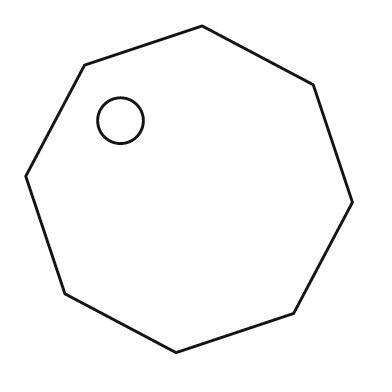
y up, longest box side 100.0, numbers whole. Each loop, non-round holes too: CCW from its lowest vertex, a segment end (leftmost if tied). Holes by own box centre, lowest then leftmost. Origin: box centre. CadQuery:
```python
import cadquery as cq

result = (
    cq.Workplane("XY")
    .moveTo(-4.0, -50.0)
    .lineTo(32.0, -38.0)
    .lineTo(50.0, -4.0)
    .lineTo(38.0, 32.0)
    .lineTo(4.0, 50.0)
    .lineTo(-32.0, 38.0)
    .lineTo(-50.0, 4.0)
    .lineTo(-38.0, -32.0)
    .close()
    .moveTo(-21.0, 21.0)
    .circle(7.0)
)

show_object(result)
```